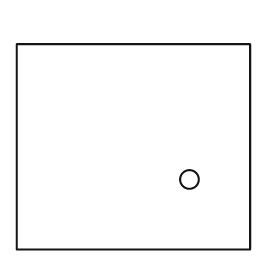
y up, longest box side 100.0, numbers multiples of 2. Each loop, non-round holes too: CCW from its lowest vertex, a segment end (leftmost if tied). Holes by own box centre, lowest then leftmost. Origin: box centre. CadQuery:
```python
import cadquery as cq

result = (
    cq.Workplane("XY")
    .moveTo(-50.0, -44.0)
    .lineTo(50.0, -44.0)
    .lineTo(50.0, 44.0)
    .lineTo(-50.0, 44.0)
    .close()
    .moveTo(24.0, -14.0)
    .circle(4.0)
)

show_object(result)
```